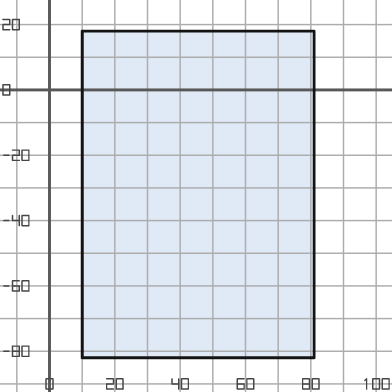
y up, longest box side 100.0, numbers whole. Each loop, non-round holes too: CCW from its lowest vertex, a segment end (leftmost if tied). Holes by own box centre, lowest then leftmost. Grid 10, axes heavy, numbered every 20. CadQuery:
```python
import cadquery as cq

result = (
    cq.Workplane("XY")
    .moveTo(10.0, -82.0)
    .lineTo(81.0, -82.0)
    .lineTo(81.0, 18.0)
    .lineTo(10.0, 18.0)
    .close()
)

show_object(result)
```